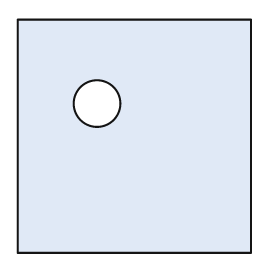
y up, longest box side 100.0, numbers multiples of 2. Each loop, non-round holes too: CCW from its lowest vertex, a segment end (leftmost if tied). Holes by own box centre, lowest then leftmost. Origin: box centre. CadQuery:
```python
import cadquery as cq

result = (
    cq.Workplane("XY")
    .moveTo(-50.0, -50.0)
    .lineTo(50.0, -50.0)
    .lineTo(50.0, 50.0)
    .lineTo(-50.0, 50.0)
    .close()
    .moveTo(-16.0, 14.0)
    .circle(10.0)
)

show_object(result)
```